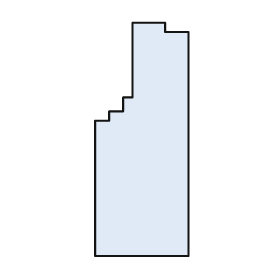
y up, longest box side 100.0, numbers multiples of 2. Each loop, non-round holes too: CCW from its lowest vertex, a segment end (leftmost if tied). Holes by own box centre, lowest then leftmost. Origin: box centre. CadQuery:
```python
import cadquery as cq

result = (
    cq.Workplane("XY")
    .moveTo(-20.0, -50.0)
    .lineTo(20.0, -50.0)
    .lineTo(20.0, 46.0)
    .lineTo(10.0, 46.0)
    .lineTo(10.0, 50.0)
    .lineTo(-4.0, 50.0)
    .lineTo(-4.0, 18.0)
    .lineTo(-8.0, 18.0)
    .lineTo(-8.0, 12.0)
    .lineTo(-14.0, 12.0)
    .lineTo(-14.0, 8.0)
    .lineTo(-20.0, 8.0)
    .close()
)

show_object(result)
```